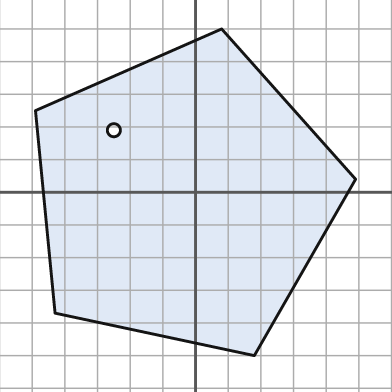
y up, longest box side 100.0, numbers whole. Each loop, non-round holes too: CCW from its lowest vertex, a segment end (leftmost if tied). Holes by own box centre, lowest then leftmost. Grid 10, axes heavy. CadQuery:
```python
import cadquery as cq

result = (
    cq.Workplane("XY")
    .moveTo(18.0, -50.0)
    .lineTo(49.0, 4.0)
    .lineTo(8.0, 50.0)
    .lineTo(-49.0, 25.0)
    .lineTo(-43.0, -37.0)
    .close()
    .moveTo(-25.0, 19.0)
    .circle(2.0)
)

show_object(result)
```